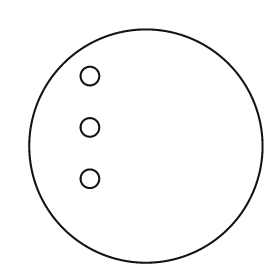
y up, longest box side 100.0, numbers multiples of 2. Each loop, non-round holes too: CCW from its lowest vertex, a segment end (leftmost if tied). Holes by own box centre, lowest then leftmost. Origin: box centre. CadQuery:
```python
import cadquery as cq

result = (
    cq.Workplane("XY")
    .moveTo(0.0, 0.0)
    .circle(50.0)
    .moveTo(-24.0, -14.0)
    .circle(4.0)
    .moveTo(-24.0, 8.0)
    .circle(4.0)
    .moveTo(-24.0, 30.0)
    .circle(4.0)
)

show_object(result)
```